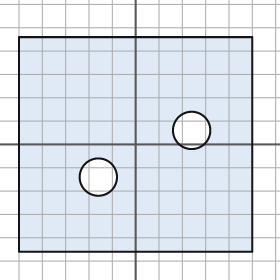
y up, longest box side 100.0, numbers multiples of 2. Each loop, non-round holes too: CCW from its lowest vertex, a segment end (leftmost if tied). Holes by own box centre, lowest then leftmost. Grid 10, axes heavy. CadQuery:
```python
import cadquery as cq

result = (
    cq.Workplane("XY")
    .moveTo(-50.0, -46.0)
    .lineTo(50.0, -46.0)
    .lineTo(50.0, 46.0)
    .lineTo(-50.0, 46.0)
    .close()
    .moveTo(-16.0, -14.0)
    .circle(8.0)
    .moveTo(24.0, 6.0)
    .circle(8.0)
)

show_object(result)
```